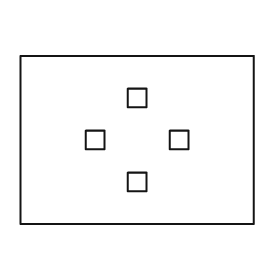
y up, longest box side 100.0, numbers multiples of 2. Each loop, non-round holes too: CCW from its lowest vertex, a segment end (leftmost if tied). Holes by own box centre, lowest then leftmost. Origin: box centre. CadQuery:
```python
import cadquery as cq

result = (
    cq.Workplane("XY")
    .moveTo(-50.0, -36.0)
    .lineTo(50.0, -36.0)
    .lineTo(50.0, 36.0)
    .lineTo(-50.0, 36.0)
    .close()
    .moveTo(-4.0, -22.0)
    .lineTo(4.0, -22.0)
    .lineTo(4.0, -14.0)
    .lineTo(-4.0, -14.0)
    .close()
    .moveTo(-22.0, -4.0)
    .lineTo(-14.0, -4.0)
    .lineTo(-14.0, 4.0)
    .lineTo(-22.0, 4.0)
    .close()
    .moveTo(14.0, -4.0)
    .lineTo(22.0, -4.0)
    .lineTo(22.0, 4.0)
    .lineTo(14.0, 4.0)
    .close()
    .moveTo(-4.0, 14.0)
    .lineTo(4.0, 14.0)
    .lineTo(4.0, 22.0)
    .lineTo(-4.0, 22.0)
    .close()
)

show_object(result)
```